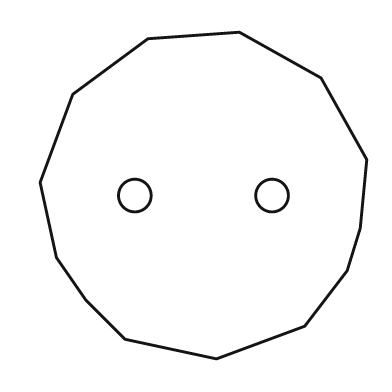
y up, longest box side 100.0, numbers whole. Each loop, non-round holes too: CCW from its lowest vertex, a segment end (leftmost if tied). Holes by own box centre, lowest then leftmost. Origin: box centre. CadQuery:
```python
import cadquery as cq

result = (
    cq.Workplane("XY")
    .moveTo(4.0, -50.0)
    .lineTo(31.0, -40.0)
    .lineTo(44.0, -23.0)
    .lineTo(48.0, -10.0)
    .lineTo(50.0, 11.0)
    .lineTo(36.0, 36.0)
    .lineTo(11.0, 50.0)
    .lineTo(-17.0, 48.0)
    .lineTo(-40.0, 31.0)
    .lineTo(-50.0, 4.0)
    .lineTo(-45.0, -19.0)
    .lineTo(-36.0, -32.0)
    .lineTo(-24.0, -44.0)
    .close()
    .moveTo(-21.0, 0.0)
    .circle(5.0)
    .moveTo(21.0, 0.0)
    .circle(5.0)
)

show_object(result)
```